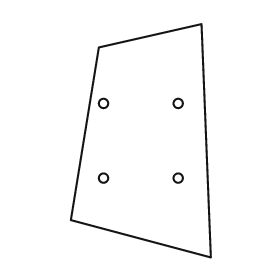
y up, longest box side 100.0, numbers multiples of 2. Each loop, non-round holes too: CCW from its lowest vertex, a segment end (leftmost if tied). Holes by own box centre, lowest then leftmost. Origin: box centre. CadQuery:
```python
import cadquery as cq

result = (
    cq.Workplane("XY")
    .moveTo(30.0, -50.0)
    .lineTo(26.0, 50.0)
    .lineTo(-18.0, 40.0)
    .lineTo(-30.0, -34.0)
    .close()
    .moveTo(-16.0, -16.0)
    .circle(2.0)
    .moveTo(16.0, -16.0)
    .circle(2.0)
    .moveTo(-16.0, 16.0)
    .circle(2.0)
    .moveTo(16.0, 16.0)
    .circle(2.0)
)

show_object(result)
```